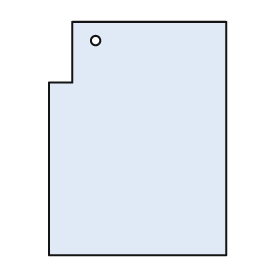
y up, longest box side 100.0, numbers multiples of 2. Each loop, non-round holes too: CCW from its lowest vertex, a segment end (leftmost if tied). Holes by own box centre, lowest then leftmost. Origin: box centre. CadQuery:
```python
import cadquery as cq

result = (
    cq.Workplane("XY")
    .moveTo(-38.0, -50.0)
    .lineTo(38.0, -50.0)
    .lineTo(38.0, 50.0)
    .lineTo(-28.0, 50.0)
    .lineTo(-28.0, 24.0)
    .lineTo(-38.0, 24.0)
    .close()
    .moveTo(-18.0, 42.0)
    .circle(2.0)
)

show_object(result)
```